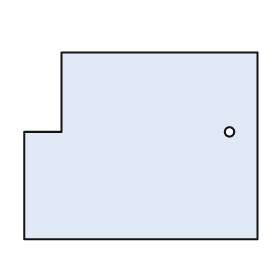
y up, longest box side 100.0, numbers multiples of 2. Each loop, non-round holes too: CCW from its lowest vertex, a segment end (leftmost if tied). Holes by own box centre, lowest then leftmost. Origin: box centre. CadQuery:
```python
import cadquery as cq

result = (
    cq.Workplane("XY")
    .moveTo(-50.0, -40.0)
    .lineTo(50.0, -40.0)
    .lineTo(50.0, 40.0)
    .lineTo(-34.0, 40.0)
    .lineTo(-34.0, 6.0)
    .lineTo(-50.0, 6.0)
    .close()
    .moveTo(38.0, 6.0)
    .circle(2.0)
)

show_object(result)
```